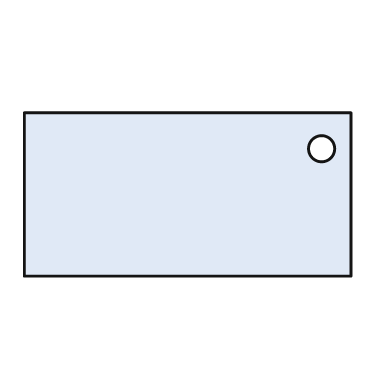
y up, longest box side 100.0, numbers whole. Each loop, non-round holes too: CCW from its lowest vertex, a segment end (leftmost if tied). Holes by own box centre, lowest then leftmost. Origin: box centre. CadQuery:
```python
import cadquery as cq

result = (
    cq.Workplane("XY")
    .moveTo(-50.0, -25.0)
    .lineTo(50.0, -25.0)
    .lineTo(50.0, 25.0)
    .lineTo(-50.0, 25.0)
    .close()
    .moveTo(41.0, 14.0)
    .circle(4.0)
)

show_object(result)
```